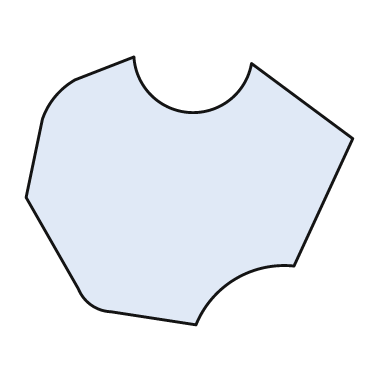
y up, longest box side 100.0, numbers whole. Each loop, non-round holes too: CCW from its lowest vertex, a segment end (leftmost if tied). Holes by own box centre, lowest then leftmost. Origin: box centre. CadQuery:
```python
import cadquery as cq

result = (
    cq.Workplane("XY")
    .moveTo(2.0, -41.0)
    .threePointArc((14.0, -27.0), (32.0, -23.0))
    .lineTo(50.0, 16.0)
    .lineTo(19.0, 39.0)
    .threePointArc((0.0, 24.0), (-17.0, 41.0))
    .lineTo(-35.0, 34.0)
    .threePointArc((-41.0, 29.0), (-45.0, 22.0))
    .lineTo(-50.0, -2.0)
    .lineTo(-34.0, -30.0)
    .threePointArc((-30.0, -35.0), (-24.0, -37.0))
    .close()
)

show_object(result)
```